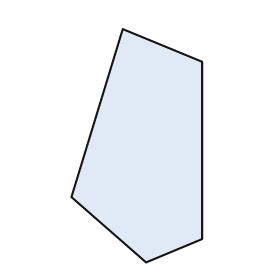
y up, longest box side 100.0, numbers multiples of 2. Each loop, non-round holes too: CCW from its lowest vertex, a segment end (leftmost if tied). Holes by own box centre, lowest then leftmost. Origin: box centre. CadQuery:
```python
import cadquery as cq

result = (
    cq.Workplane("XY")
    .moveTo(4.0, -50.0)
    .lineTo(28.0, -40.0)
    .lineTo(28.0, 36.0)
    .lineTo(-6.0, 50.0)
    .lineTo(-28.0, -22.0)
    .close()
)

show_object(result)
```